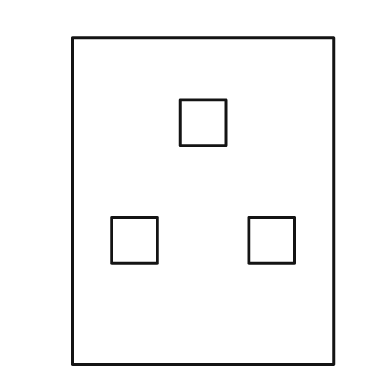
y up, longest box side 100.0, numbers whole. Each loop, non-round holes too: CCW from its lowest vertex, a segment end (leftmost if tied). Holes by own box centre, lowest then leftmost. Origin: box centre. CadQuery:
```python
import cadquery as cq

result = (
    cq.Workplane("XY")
    .moveTo(-40.0, -50.0)
    .lineTo(40.0, -50.0)
    .lineTo(40.0, 50.0)
    .lineTo(-40.0, 50.0)
    .close()
    .moveTo(-28.0, -19.0)
    .lineTo(-14.0, -19.0)
    .lineTo(-14.0, -5.0)
    .lineTo(-28.0, -5.0)
    .close()
    .moveTo(14.0, -19.0)
    .lineTo(28.0, -19.0)
    .lineTo(28.0, -5.0)
    .lineTo(14.0, -5.0)
    .close()
    .moveTo(-7.0, 17.0)
    .lineTo(7.0, 17.0)
    .lineTo(7.0, 31.0)
    .lineTo(-7.0, 31.0)
    .close()
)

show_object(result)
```